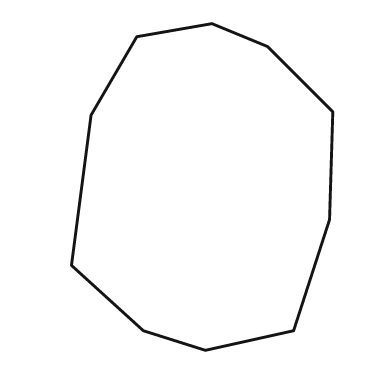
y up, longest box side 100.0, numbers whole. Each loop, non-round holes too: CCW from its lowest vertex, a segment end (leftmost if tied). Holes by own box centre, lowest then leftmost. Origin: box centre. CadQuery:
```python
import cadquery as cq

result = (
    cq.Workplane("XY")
    .moveTo(1.0, -50.0)
    .lineTo(28.0, -44.0)
    .lineTo(39.0, -10.0)
    .lineTo(40.0, 23.0)
    .lineTo(20.0, 43.0)
    .lineTo(3.0, 50.0)
    .lineTo(-20.0, 46.0)
    .lineTo(-34.0, 22.0)
    .lineTo(-40.0, -24.0)
    .lineTo(-18.0, -44.0)
    .close()
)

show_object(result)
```